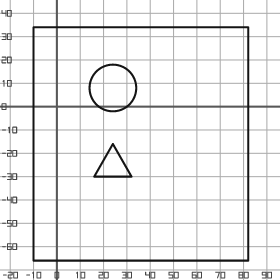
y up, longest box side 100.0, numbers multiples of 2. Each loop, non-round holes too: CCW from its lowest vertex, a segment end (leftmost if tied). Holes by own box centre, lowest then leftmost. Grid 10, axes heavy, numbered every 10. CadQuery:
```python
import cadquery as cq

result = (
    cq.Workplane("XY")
    .moveTo(-10.0, -66.0)
    .lineTo(82.0, -66.0)
    .lineTo(82.0, 34.0)
    .lineTo(-10.0, 34.0)
    .close()
    .moveTo(16.0, -30.0)
    .lineTo(32.0, -30.0)
    .lineTo(24.0, -16.0)
    .close()
    .moveTo(24.0, 8.0)
    .circle(10.0)
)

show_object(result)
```